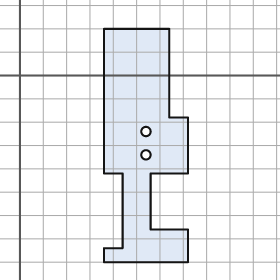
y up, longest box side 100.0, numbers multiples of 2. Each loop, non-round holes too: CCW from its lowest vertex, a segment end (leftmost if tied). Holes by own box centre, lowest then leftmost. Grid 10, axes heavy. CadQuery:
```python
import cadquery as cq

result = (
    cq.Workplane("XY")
    .moveTo(36.0, -80.0)
    .lineTo(72.0, -80.0)
    .lineTo(72.0, -66.0)
    .lineTo(56.0, -66.0)
    .lineTo(56.0, -42.0)
    .lineTo(72.0, -42.0)
    .lineTo(72.0, -18.0)
    .lineTo(64.0, -18.0)
    .lineTo(64.0, 20.0)
    .lineTo(36.0, 20.0)
    .lineTo(36.0, -42.0)
    .lineTo(44.0, -42.0)
    .lineTo(44.0, -74.0)
    .lineTo(36.0, -74.0)
    .close()
    .moveTo(54.0, -34.0)
    .circle(2.0)
    .moveTo(54.0, -24.0)
    .circle(2.0)
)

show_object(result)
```